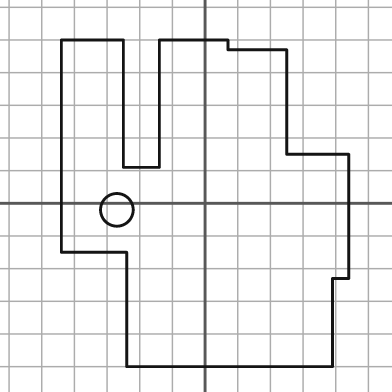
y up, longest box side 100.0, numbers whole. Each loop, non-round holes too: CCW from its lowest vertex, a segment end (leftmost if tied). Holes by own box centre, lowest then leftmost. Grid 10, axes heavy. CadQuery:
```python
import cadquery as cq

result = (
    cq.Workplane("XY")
    .moveTo(-24.0, -50.0)
    .lineTo(39.0, -50.0)
    .lineTo(39.0, -23.0)
    .lineTo(44.0, -23.0)
    .lineTo(44.0, 15.0)
    .lineTo(25.0, 15.0)
    .lineTo(25.0, 47.0)
    .lineTo(7.0, 47.0)
    .lineTo(7.0, 50.0)
    .lineTo(-14.0, 50.0)
    .lineTo(-14.0, 11.0)
    .lineTo(-25.0, 11.0)
    .lineTo(-25.0, 50.0)
    .lineTo(-44.0, 50.0)
    .lineTo(-44.0, -15.0)
    .lineTo(-24.0, -15.0)
    .close()
    .moveTo(-27.0, -2.0)
    .circle(5.0)
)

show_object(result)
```